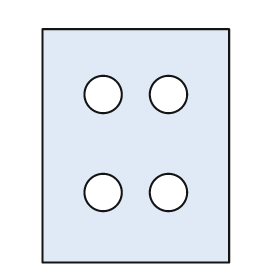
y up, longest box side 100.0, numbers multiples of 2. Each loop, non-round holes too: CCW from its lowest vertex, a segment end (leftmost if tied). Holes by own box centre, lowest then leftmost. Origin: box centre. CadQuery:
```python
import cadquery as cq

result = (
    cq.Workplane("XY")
    .moveTo(-40.0, -50.0)
    .lineTo(40.0, -50.0)
    .lineTo(40.0, 50.0)
    .lineTo(-40.0, 50.0)
    .close()
    .moveTo(-14.0, -20.0)
    .circle(8.0)
    .moveTo(14.0, -20.0)
    .circle(8.0)
    .moveTo(-14.0, 22.0)
    .circle(8.0)
    .moveTo(14.0, 22.0)
    .circle(8.0)
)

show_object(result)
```